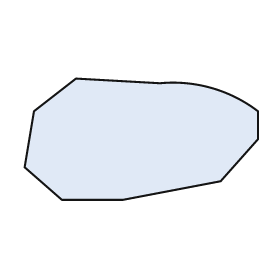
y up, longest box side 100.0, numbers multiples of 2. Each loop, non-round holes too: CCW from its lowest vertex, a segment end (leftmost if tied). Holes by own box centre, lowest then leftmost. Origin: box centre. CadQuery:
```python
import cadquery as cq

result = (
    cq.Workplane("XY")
    .moveTo(-34.0, -26.0)
    .lineTo(-8.0, -26.0)
    .lineTo(34.0, -18.0)
    .lineTo(50.0, 0.0)
    .lineTo(50.0, 12.0)
    .threePointArc((30.0, 22.0), (8.0, 24.0))
    .lineTo(-28.0, 26.0)
    .lineTo(-46.0, 12.0)
    .lineTo(-50.0, -12.0)
    .close()
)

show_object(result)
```